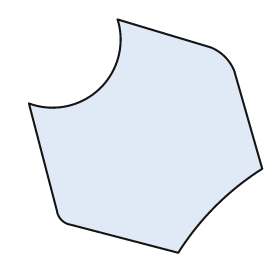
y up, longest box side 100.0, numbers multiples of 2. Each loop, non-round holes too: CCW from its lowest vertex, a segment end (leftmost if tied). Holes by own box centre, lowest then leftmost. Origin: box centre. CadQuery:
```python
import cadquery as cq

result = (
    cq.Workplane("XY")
    .moveTo(14.0, -50.0)
    .threePointArc((30.0, -30.0), (50.0, -14.0))
    .lineTo(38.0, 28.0)
    .threePointArc((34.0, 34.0), (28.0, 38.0))
    .lineTo(-12.0, 50.0)
    .threePointArc((-20.0, 20.0), (-50.0, 14.0))
    .lineTo(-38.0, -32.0)
    .threePointArc((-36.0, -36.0), (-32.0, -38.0))
    .close()
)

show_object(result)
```